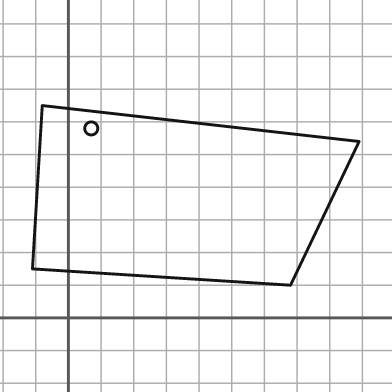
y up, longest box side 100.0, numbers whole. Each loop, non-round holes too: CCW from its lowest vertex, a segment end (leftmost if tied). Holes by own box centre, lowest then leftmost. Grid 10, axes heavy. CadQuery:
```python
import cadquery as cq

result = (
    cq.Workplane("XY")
    .moveTo(68.0, 10.0)
    .lineTo(89.0, 54.0)
    .lineTo(-8.0, 65.0)
    .lineTo(-11.0, 15.0)
    .close()
    .moveTo(7.0, 58.0)
    .circle(2.0)
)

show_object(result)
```